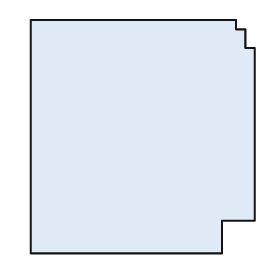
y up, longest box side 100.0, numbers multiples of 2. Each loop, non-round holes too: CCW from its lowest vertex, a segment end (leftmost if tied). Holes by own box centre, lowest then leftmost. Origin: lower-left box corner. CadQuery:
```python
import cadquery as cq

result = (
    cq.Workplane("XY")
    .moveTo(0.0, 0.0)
    .lineTo(82.0, 0.0)
    .lineTo(82.0, 14.0)
    .lineTo(96.0, 14.0)
    .lineTo(96.0, 88.0)
    .lineTo(92.0, 88.0)
    .lineTo(92.0, 96.0)
    .lineTo(88.0, 96.0)
    .lineTo(88.0, 100.0)
    .lineTo(0.0, 100.0)
    .close()
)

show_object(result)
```